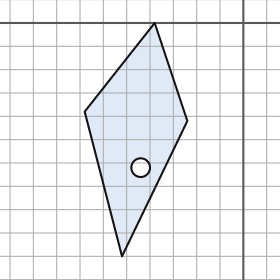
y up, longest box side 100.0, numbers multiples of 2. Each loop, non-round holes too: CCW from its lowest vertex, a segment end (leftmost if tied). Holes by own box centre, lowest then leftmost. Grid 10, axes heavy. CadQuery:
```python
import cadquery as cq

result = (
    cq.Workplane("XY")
    .moveTo(-52.0, -100.0)
    .lineTo(-24.0, -42.0)
    .lineTo(-38.0, 0.0)
    .lineTo(-68.0, -38.0)
    .close()
    .moveTo(-44.0, -62.0)
    .circle(4.0)
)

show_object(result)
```